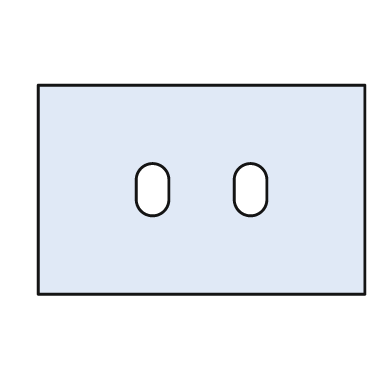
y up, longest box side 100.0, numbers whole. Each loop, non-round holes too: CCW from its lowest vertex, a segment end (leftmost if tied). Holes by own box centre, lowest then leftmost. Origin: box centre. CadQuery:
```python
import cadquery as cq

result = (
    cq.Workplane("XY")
    .moveTo(-50.0, -32.0)
    .lineTo(50.0, -32.0)
    .lineTo(50.0, 32.0)
    .lineTo(-50.0, 32.0)
    .close()
    .moveTo(-20.0, -3.0)
    .threePointArc((-15.0, -8.0), (-10.0, -3.0))
    .lineTo(-10.0, 3.0)
    .threePointArc((-15.0, 8.0), (-20.0, 3.0))
    .close()
    .moveTo(10.0, -3.0)
    .threePointArc((15.0, -8.0), (20.0, -3.0))
    .lineTo(20.0, 3.0)
    .threePointArc((15.0, 8.0), (10.0, 3.0))
    .close()
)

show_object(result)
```